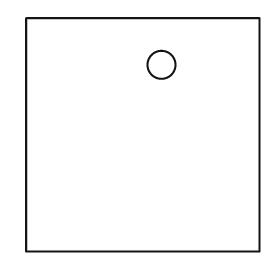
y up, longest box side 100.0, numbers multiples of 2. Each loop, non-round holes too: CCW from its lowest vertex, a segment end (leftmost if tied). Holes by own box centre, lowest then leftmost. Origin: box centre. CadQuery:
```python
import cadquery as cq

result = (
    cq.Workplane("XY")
    .moveTo(-50.0, -50.0)
    .lineTo(50.0, -50.0)
    .lineTo(50.0, 50.0)
    .lineTo(-50.0, 50.0)
    .close()
    .moveTo(8.0, 30.0)
    .circle(6.0)
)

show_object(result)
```